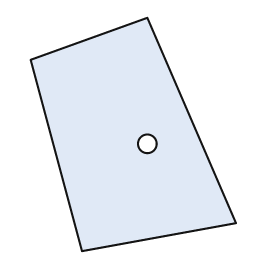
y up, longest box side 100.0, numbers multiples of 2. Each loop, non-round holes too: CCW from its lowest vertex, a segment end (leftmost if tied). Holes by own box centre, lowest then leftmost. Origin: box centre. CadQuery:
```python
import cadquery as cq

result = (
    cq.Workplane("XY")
    .moveTo(-22.0, -50.0)
    .lineTo(44.0, -38.0)
    .lineTo(6.0, 50.0)
    .lineTo(-44.0, 32.0)
    .close()
    .moveTo(6.0, -4.0)
    .circle(4.0)
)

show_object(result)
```